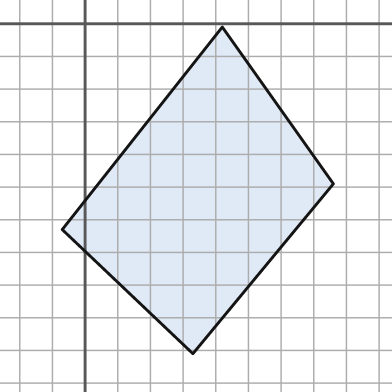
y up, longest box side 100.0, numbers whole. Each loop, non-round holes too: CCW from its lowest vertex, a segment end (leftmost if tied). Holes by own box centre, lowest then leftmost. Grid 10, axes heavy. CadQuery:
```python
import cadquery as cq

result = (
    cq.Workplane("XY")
    .moveTo(33.0, -101.0)
    .lineTo(76.0, -49.0)
    .lineTo(42.0, -1.0)
    .lineTo(-7.0, -63.0)
    .close()
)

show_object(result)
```